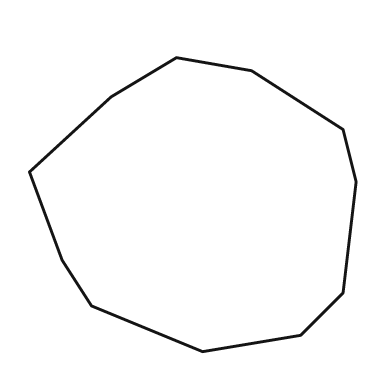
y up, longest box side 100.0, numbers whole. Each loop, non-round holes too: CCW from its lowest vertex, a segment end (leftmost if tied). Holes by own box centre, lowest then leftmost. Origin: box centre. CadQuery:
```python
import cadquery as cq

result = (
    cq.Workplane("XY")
    .moveTo(3.0, -45.0)
    .lineTo(33.0, -40.0)
    .lineTo(46.0, -27.0)
    .lineTo(50.0, 7.0)
    .lineTo(46.0, 23.0)
    .lineTo(18.0, 41.0)
    .lineTo(-5.0, 45.0)
    .lineTo(-25.0, 33.0)
    .lineTo(-50.0, 10.0)
    .lineTo(-40.0, -17.0)
    .lineTo(-31.0, -31.0)
    .close()
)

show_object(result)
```